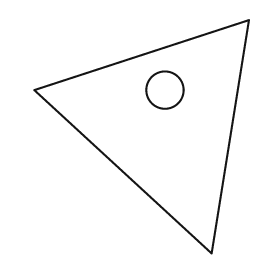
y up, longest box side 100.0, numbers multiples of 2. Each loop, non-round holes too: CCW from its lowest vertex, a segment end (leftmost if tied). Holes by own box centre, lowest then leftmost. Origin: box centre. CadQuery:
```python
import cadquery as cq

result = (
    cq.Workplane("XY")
    .moveTo(30.0, -50.0)
    .lineTo(46.0, 50.0)
    .lineTo(-46.0, 20.0)
    .close()
    .moveTo(10.0, 20.0)
    .circle(8.0)
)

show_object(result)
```